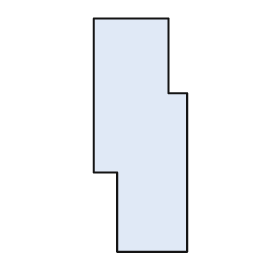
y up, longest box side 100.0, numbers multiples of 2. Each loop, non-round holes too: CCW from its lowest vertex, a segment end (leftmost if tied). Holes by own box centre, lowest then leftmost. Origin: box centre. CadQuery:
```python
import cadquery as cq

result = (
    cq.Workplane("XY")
    .moveTo(-10.0, -50.0)
    .lineTo(20.0, -50.0)
    .lineTo(20.0, 18.0)
    .lineTo(12.0, 18.0)
    .lineTo(12.0, 50.0)
    .lineTo(-20.0, 50.0)
    .lineTo(-20.0, -16.0)
    .lineTo(-10.0, -16.0)
    .close()
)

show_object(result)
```